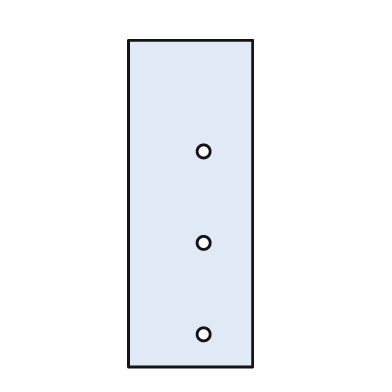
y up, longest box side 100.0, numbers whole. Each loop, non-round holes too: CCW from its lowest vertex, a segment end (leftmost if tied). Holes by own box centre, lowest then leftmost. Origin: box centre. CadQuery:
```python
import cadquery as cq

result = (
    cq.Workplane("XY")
    .moveTo(-19.0, -50.0)
    .lineTo(19.0, -50.0)
    .lineTo(19.0, 50.0)
    .lineTo(-19.0, 50.0)
    .close()
    .moveTo(4.0, -40.0)
    .circle(2.0)
    .moveTo(4.0, -12.0)
    .circle(2.0)
    .moveTo(4.0, 16.0)
    .circle(2.0)
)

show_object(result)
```